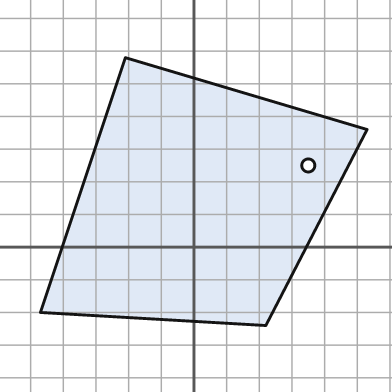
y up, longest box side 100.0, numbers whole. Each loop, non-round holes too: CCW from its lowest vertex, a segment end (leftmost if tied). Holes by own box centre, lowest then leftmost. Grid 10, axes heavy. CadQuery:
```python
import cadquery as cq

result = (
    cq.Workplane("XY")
    .moveTo(22.0, -24.0)
    .lineTo(53.0, 36.0)
    .lineTo(-21.0, 58.0)
    .lineTo(-47.0, -20.0)
    .close()
    .moveTo(35.0, 25.0)
    .circle(2.0)
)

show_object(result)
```